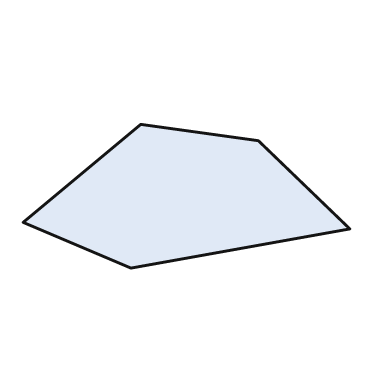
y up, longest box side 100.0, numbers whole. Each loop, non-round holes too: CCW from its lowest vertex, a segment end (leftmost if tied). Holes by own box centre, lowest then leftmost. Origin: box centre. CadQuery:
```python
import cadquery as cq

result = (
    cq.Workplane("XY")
    .moveTo(-17.0, -22.0)
    .lineTo(50.0, -10.0)
    .lineTo(22.0, 17.0)
    .lineTo(-14.0, 22.0)
    .lineTo(-50.0, -8.0)
    .close()
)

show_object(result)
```